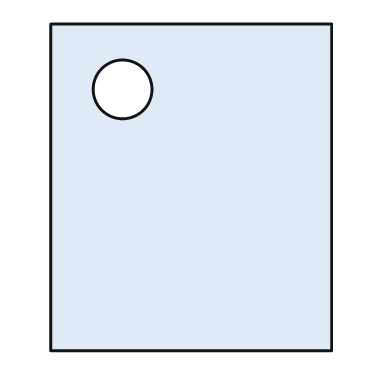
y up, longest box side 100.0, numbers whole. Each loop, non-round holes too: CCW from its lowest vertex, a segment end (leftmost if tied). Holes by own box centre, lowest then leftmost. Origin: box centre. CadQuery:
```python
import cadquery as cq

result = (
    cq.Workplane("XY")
    .moveTo(-43.0, -50.0)
    .lineTo(43.0, -50.0)
    .lineTo(43.0, 50.0)
    .lineTo(-43.0, 50.0)
    .close()
    .moveTo(-21.0, 30.0)
    .circle(9.0)
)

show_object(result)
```